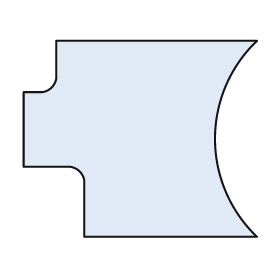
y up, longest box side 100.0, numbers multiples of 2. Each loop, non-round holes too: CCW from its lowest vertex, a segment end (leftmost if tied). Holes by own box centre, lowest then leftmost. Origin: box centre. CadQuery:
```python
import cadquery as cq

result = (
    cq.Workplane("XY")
    .moveTo(-24.0, -42.0)
    .lineTo(50.0, -42.0)
    .threePointArc((32.0, 0.0), (50.0, 42.0))
    .lineTo(-36.0, 42.0)
    .lineTo(-36.0, 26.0)
    .threePointArc((-38.0, 22.0), (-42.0, 20.0))
    .lineTo(-50.0, 20.0)
    .lineTo(-50.0, -12.0)
    .lineTo(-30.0, -12.0)
    .threePointArc((-26.0, -14.0), (-24.0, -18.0))
    .close()
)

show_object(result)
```